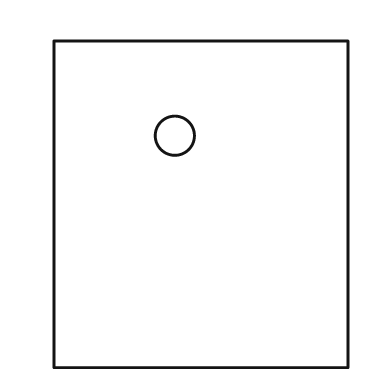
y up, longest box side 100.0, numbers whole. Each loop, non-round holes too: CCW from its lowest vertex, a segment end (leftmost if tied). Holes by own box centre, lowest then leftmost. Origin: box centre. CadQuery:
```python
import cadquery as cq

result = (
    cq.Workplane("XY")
    .moveTo(-45.0, -50.0)
    .lineTo(45.0, -50.0)
    .lineTo(45.0, 50.0)
    .lineTo(-45.0, 50.0)
    .close()
    .moveTo(-8.0, 21.0)
    .circle(6.0)
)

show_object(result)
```